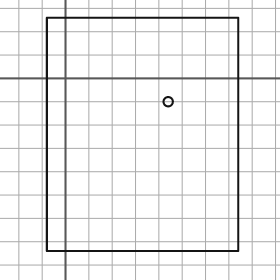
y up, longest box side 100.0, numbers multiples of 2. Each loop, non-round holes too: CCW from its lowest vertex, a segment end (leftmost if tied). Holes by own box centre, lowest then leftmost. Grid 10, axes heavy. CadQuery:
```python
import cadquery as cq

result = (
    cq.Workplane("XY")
    .moveTo(-8.0, -74.0)
    .lineTo(74.0, -74.0)
    .lineTo(74.0, 26.0)
    .lineTo(-8.0, 26.0)
    .close()
    .moveTo(44.0, -10.0)
    .circle(2.0)
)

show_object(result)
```